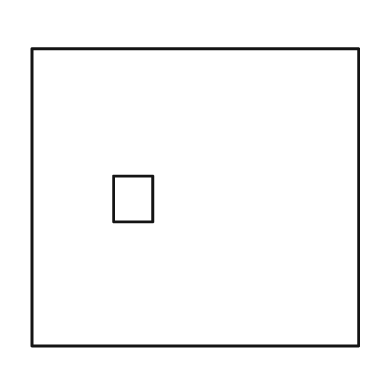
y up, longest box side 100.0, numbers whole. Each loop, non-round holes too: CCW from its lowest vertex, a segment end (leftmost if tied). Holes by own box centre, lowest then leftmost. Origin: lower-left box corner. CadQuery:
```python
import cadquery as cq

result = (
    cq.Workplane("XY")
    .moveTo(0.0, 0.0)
    .lineTo(100.0, 0.0)
    .lineTo(100.0, 91.0)
    .lineTo(0.0, 91.0)
    .close()
    .moveTo(25.0, 38.0)
    .lineTo(37.0, 38.0)
    .lineTo(37.0, 52.0)
    .lineTo(25.0, 52.0)
    .close()
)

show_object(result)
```